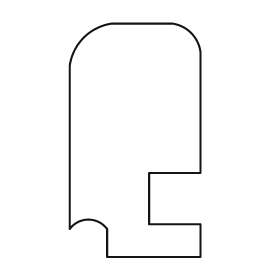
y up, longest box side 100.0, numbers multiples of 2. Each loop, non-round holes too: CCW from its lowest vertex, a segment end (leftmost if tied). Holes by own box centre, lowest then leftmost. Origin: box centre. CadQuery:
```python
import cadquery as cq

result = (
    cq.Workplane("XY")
    .moveTo(-12.0, -50.0)
    .lineTo(28.0, -50.0)
    .lineTo(28.0, -36.0)
    .lineTo(6.0, -36.0)
    .lineTo(6.0, -14.0)
    .lineTo(28.0, -14.0)
    .lineTo(28.0, 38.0)
    .threePointArc((24.0, 46.0), (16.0, 50.0))
    .lineTo(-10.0, 50.0)
    .threePointArc((-22.0, 44.0), (-28.0, 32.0))
    .lineTo(-28.0, -38.0)
    .threePointArc((-20.0, -34.0), (-12.0, -38.0))
    .close()
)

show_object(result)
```